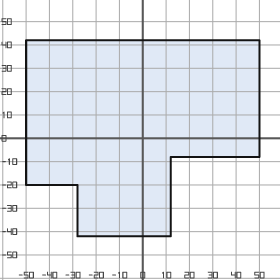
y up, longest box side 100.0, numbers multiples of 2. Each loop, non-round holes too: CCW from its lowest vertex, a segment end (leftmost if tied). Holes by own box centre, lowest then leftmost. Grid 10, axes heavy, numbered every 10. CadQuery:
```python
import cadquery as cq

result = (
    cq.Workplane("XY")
    .moveTo(-28.0, -42.0)
    .lineTo(12.0, -42.0)
    .lineTo(12.0, -8.0)
    .lineTo(50.0, -8.0)
    .lineTo(50.0, 42.0)
    .lineTo(-50.0, 42.0)
    .lineTo(-50.0, -20.0)
    .lineTo(-28.0, -20.0)
    .close()
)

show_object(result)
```